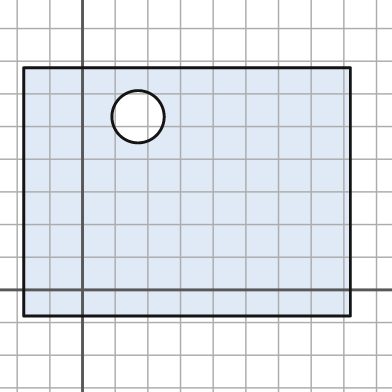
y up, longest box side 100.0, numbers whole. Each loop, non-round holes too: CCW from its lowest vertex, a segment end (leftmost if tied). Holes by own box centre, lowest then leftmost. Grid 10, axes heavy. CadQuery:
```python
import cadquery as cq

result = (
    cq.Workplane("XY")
    .moveTo(-18.0, -8.0)
    .lineTo(82.0, -8.0)
    .lineTo(82.0, 68.0)
    .lineTo(-18.0, 68.0)
    .close()
    .moveTo(17.0, 53.0)
    .circle(8.0)
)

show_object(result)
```